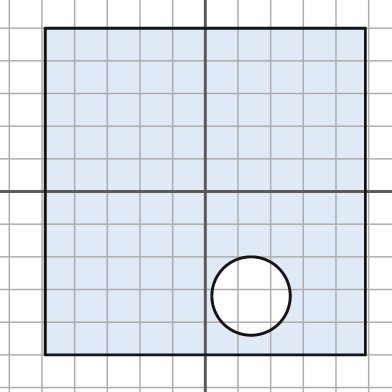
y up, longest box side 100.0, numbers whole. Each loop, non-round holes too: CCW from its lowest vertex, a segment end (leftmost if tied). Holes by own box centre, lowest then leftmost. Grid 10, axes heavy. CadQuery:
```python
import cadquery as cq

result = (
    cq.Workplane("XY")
    .moveTo(-49.0, -50.0)
    .lineTo(49.0, -50.0)
    .lineTo(49.0, 50.0)
    .lineTo(-49.0, 50.0)
    .close()
    .moveTo(14.0, -32.0)
    .circle(12.0)
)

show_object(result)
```